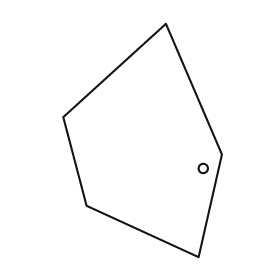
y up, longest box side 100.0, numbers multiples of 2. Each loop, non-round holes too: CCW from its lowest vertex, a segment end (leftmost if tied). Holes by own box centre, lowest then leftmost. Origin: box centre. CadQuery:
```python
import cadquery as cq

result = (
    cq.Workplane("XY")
    .moveTo(24.0, -50.0)
    .lineTo(34.0, -6.0)
    .lineTo(10.0, 50.0)
    .lineTo(-34.0, 10.0)
    .lineTo(-24.0, -28.0)
    .close()
    .moveTo(26.0, -12.0)
    .circle(2.0)
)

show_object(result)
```